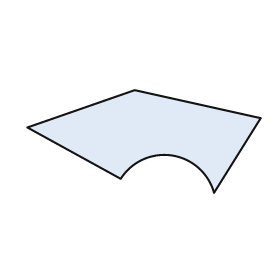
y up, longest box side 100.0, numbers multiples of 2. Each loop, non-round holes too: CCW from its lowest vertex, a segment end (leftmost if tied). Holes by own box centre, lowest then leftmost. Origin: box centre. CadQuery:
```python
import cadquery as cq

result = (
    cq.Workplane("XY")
    .moveTo(30.0, -22.0)
    .lineTo(50.0, 10.0)
    .lineTo(-4.0, 22.0)
    .lineTo(-50.0, 6.0)
    .lineTo(-10.0, -16.0)
    .threePointArc((12.0, -6.0), (30.0, -22.0))
    .close()
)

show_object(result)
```